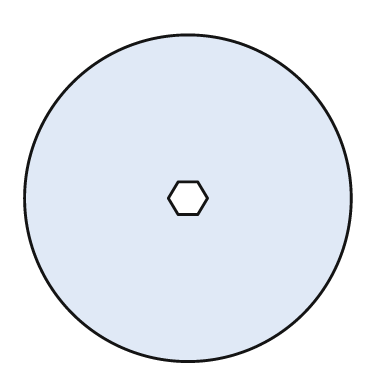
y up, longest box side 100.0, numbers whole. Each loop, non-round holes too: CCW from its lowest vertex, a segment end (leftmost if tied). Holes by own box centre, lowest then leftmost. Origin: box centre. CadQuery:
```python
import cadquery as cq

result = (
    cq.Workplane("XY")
    .moveTo(0.0, 0.0)
    .circle(50.0)
    .moveTo(-3.0, -5.0)
    .lineTo(3.0, -5.0)
    .lineTo(6.0, 0.0)
    .lineTo(3.0, 5.0)
    .lineTo(-3.0, 5.0)
    .lineTo(-6.0, 0.0)
    .close()
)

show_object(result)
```